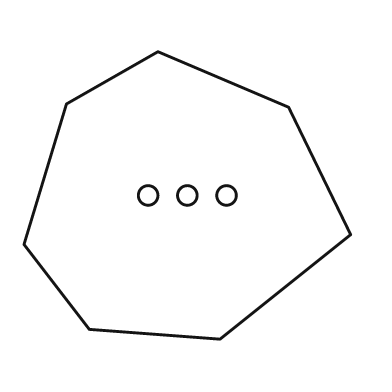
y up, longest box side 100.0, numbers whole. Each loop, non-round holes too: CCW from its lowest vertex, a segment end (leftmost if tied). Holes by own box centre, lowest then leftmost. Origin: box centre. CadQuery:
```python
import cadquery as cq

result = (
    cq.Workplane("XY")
    .moveTo(10.0, -44.0)
    .lineTo(50.0, -12.0)
    .lineTo(31.0, 27.0)
    .lineTo(-9.0, 44.0)
    .lineTo(-37.0, 28.0)
    .lineTo(-50.0, -15.0)
    .lineTo(-30.0, -41.0)
    .close()
    .moveTo(-12.0, 0.0)
    .circle(3.0)
    .moveTo(0.0, 0.0)
    .circle(3.0)
    .moveTo(12.0, 0.0)
    .circle(3.0)
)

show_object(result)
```